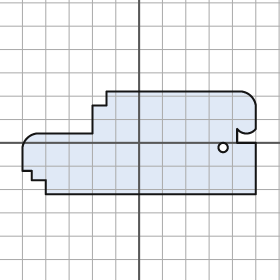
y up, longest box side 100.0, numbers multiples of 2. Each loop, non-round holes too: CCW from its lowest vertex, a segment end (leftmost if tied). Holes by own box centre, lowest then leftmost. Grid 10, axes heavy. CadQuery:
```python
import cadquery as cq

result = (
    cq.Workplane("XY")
    .moveTo(-40.0, -22.0)
    .lineTo(50.0, -22.0)
    .lineTo(50.0, 0.0)
    .lineTo(42.0, 0.0)
    .lineTo(42.0, 6.0)
    .threePointArc((46.0, 4.0), (50.0, 6.0))
    .lineTo(50.0, 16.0)
    .threePointArc((48.0, 20.0), (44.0, 22.0))
    .lineTo(-14.0, 22.0)
    .lineTo(-14.0, 16.0)
    .lineTo(-20.0, 16.0)
    .lineTo(-20.0, 4.0)
    .lineTo(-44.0, 4.0)
    .threePointArc((-48.0, 2.0), (-50.0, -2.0))
    .lineTo(-50.0, -12.0)
    .lineTo(-46.0, -12.0)
    .lineTo(-46.0, -16.0)
    .lineTo(-40.0, -16.0)
    .close()
    .moveTo(36.0, -2.0)
    .circle(2.0)
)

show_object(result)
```